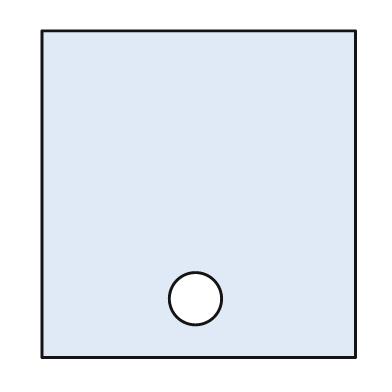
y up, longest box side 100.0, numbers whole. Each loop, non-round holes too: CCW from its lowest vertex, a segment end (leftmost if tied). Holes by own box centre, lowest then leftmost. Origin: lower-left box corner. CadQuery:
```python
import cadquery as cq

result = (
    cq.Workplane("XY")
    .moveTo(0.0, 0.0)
    .lineTo(96.0, 0.0)
    .lineTo(96.0, 100.0)
    .lineTo(0.0, 100.0)
    .close()
    .moveTo(47.0, 18.0)
    .circle(8.0)
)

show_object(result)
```